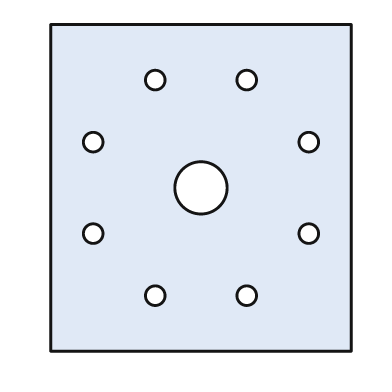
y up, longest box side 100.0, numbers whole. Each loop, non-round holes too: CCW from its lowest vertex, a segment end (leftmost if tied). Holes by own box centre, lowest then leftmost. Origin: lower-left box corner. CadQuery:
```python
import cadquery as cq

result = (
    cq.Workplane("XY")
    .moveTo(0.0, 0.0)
    .lineTo(92.0, 0.0)
    .lineTo(92.0, 100.0)
    .lineTo(0.0, 100.0)
    .close()
    .moveTo(32.0, 17.0)
    .circle(3.0)
    .moveTo(60.0, 17.0)
    .circle(3.0)
    .moveTo(13.0, 36.0)
    .circle(3.0)
    .moveTo(79.0, 36.0)
    .circle(3.0)
    .moveTo(46.0, 50.0)
    .circle(8.0)
    .moveTo(13.0, 64.0)
    .circle(3.0)
    .moveTo(79.0, 64.0)
    .circle(3.0)
    .moveTo(32.0, 83.0)
    .circle(3.0)
    .moveTo(60.0, 83.0)
    .circle(3.0)
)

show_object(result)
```